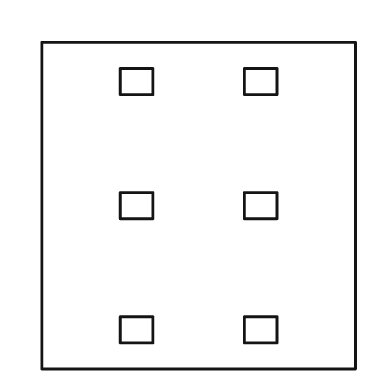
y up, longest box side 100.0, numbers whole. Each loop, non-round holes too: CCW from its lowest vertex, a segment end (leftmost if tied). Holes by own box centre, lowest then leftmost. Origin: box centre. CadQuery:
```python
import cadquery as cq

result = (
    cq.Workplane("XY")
    .moveTo(-48.0, -50.0)
    .lineTo(48.0, -50.0)
    .lineTo(48.0, 50.0)
    .lineTo(-48.0, 50.0)
    .close()
    .moveTo(-24.0, -42.0)
    .lineTo(-14.0, -42.0)
    .lineTo(-14.0, -34.0)
    .lineTo(-24.0, -34.0)
    .close()
    .moveTo(14.0, -42.0)
    .lineTo(24.0, -42.0)
    .lineTo(24.0, -34.0)
    .lineTo(14.0, -34.0)
    .close()
    .moveTo(-24.0, -4.0)
    .lineTo(-14.0, -4.0)
    .lineTo(-14.0, 4.0)
    .lineTo(-24.0, 4.0)
    .close()
    .moveTo(14.0, -4.0)
    .lineTo(24.0, -4.0)
    .lineTo(24.0, 4.0)
    .lineTo(14.0, 4.0)
    .close()
    .moveTo(-24.0, 34.0)
    .lineTo(-14.0, 34.0)
    .lineTo(-14.0, 42.0)
    .lineTo(-24.0, 42.0)
    .close()
    .moveTo(14.0, 34.0)
    .lineTo(24.0, 34.0)
    .lineTo(24.0, 42.0)
    .lineTo(14.0, 42.0)
    .close()
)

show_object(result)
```